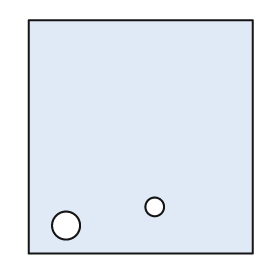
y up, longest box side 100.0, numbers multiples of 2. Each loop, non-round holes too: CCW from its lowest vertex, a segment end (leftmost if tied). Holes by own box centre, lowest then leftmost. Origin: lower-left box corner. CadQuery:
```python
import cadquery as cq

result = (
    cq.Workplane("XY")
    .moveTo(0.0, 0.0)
    .lineTo(96.0, 0.0)
    .lineTo(96.0, 100.0)
    .lineTo(0.0, 100.0)
    .close()
    .moveTo(16.0, 12.0)
    .circle(6.0)
    .moveTo(54.0, 20.0)
    .circle(4.0)
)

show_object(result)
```